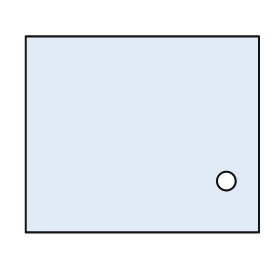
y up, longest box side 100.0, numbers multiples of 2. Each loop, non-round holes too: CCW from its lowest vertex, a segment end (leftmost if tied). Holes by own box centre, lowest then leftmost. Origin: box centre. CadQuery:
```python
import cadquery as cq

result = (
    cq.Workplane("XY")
    .moveTo(-50.0, -42.0)
    .lineTo(50.0, -42.0)
    .lineTo(50.0, 42.0)
    .lineTo(-50.0, 42.0)
    .close()
    .moveTo(36.0, -20.0)
    .circle(4.0)
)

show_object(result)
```